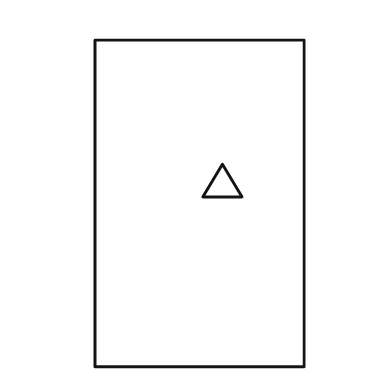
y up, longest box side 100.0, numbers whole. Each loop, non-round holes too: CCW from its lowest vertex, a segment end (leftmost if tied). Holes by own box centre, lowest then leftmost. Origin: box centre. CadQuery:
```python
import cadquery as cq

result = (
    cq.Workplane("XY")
    .moveTo(-32.0, -50.0)
    .lineTo(32.0, -50.0)
    .lineTo(32.0, 50.0)
    .lineTo(-32.0, 50.0)
    .close()
    .moveTo(1.0, 2.0)
    .lineTo(13.0, 2.0)
    .lineTo(7.0, 12.0)
    .close()
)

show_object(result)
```